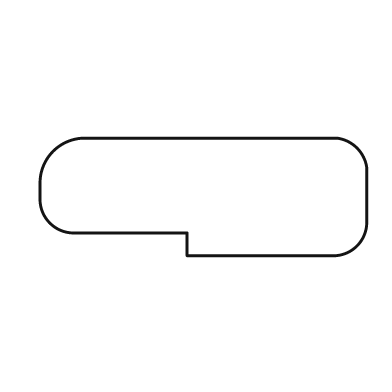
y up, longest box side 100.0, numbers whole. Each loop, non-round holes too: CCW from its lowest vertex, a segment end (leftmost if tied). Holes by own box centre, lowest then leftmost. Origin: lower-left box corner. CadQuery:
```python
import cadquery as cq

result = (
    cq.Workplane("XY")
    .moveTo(45.0, 0.0)
    .lineTo(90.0, 0.0)
    .threePointArc((97.0, 3.0), (100.0, 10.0))
    .lineTo(100.0, 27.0)
    .threePointArc((97.0, 33.0), (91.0, 36.0))
    .lineTo(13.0, 36.0)
    .threePointArc((4.0, 32.0), (0.0, 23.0))
    .lineTo(0.0, 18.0)
    .threePointArc((3.0, 10.0), (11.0, 7.0))
    .lineTo(45.0, 7.0)
    .close()
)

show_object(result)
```